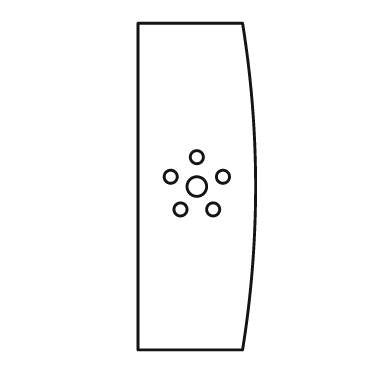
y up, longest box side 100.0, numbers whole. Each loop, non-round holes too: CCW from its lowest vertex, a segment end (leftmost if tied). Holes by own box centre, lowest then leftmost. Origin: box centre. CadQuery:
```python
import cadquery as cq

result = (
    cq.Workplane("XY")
    .moveTo(-18.0, -50.0)
    .lineTo(14.0, -50.0)
    .threePointArc((18.0, 0.0), (14.0, 50.0))
    .lineTo(-18.0, 50.0)
    .close()
    .moveTo(-5.0, -7.0)
    .circle(2.0)
    .moveTo(5.0, -7.0)
    .circle(2.0)
    .moveTo(0.0, 0.0)
    .circle(3.0)
    .moveTo(-8.0, 3.0)
    .circle(2.0)
    .moveTo(8.0, 3.0)
    .circle(2.0)
    .moveTo(0.0, 9.0)
    .circle(2.0)
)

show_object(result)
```